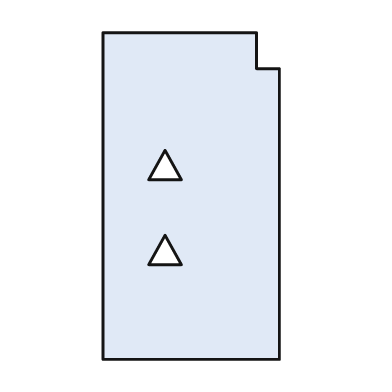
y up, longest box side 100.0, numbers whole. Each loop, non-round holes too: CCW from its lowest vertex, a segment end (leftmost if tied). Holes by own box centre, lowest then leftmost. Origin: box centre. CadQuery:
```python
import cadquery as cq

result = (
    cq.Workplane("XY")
    .moveTo(-27.0, -50.0)
    .lineTo(27.0, -50.0)
    .lineTo(27.0, 39.0)
    .lineTo(20.0, 39.0)
    .lineTo(20.0, 50.0)
    .lineTo(-27.0, 50.0)
    .close()
    .moveTo(-13.0, -21.0)
    .lineTo(-3.0, -21.0)
    .lineTo(-8.0, -12.0)
    .close()
    .moveTo(-13.0, 5.0)
    .lineTo(-3.0, 5.0)
    .lineTo(-8.0, 14.0)
    .close()
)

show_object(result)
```